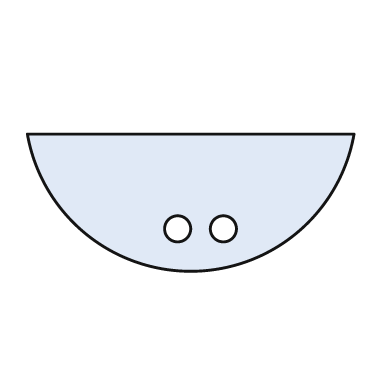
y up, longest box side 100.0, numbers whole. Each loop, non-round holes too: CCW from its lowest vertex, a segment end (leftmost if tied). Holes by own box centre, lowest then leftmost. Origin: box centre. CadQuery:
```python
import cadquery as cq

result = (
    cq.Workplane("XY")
    .moveTo(-50.0, 21.0)
    .threePointArc((0.0, -21.0), (50.0, 21.0))
    .close()
    .moveTo(-4.0, -8.0)
    .circle(4.0)
    .moveTo(10.0, -8.0)
    .circle(4.0)
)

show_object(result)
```